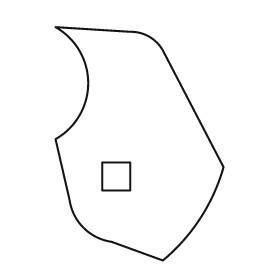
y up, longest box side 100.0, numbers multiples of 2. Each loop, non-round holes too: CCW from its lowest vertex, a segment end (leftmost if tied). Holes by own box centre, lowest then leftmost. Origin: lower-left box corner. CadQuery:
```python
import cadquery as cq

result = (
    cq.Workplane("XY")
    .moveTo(46.0, 0.0)
    .threePointArc((62.0, 18.0), (72.0, 40.0))
    .lineTo(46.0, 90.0)
    .threePointArc((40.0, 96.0), (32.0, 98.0))
    .lineTo(0.0, 100.0)
    .threePointArc((14.0, 76.0), (0.0, 52.0))
    .lineTo(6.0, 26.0)
    .threePointArc((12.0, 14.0), (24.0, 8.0))
    .close()
    .moveTo(20.0, 30.0)
    .lineTo(32.0, 30.0)
    .lineTo(32.0, 42.0)
    .lineTo(20.0, 42.0)
    .close()
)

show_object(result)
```